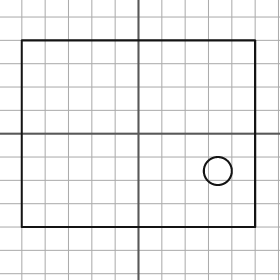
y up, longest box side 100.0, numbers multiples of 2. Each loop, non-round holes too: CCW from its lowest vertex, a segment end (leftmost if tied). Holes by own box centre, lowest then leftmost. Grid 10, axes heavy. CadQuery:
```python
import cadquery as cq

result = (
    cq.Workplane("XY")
    .moveTo(-50.0, -40.0)
    .lineTo(50.0, -40.0)
    .lineTo(50.0, 40.0)
    .lineTo(-50.0, 40.0)
    .close()
    .moveTo(34.0, -16.0)
    .circle(6.0)
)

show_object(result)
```